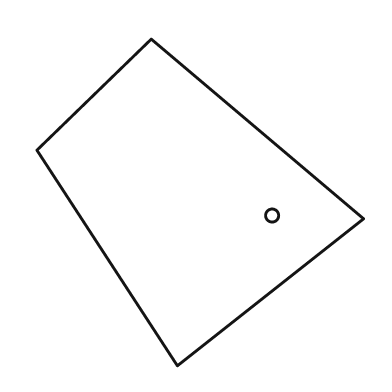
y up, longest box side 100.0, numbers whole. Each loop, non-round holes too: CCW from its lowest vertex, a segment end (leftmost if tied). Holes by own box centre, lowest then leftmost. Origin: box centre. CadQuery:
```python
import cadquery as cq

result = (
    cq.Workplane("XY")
    .moveTo(-7.0, -50.0)
    .lineTo(50.0, -5.0)
    .lineTo(-15.0, 50.0)
    .lineTo(-50.0, 16.0)
    .close()
    .moveTo(22.0, -4.0)
    .circle(2.0)
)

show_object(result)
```